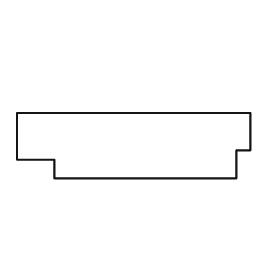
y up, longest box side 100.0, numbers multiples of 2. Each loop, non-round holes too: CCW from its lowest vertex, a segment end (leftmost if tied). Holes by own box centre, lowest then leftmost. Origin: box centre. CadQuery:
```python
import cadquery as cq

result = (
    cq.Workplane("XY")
    .moveTo(-34.0, -14.0)
    .lineTo(44.0, -14.0)
    .lineTo(44.0, -2.0)
    .lineTo(50.0, -2.0)
    .lineTo(50.0, 14.0)
    .lineTo(-50.0, 14.0)
    .lineTo(-50.0, -6.0)
    .lineTo(-34.0, -6.0)
    .close()
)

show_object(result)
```